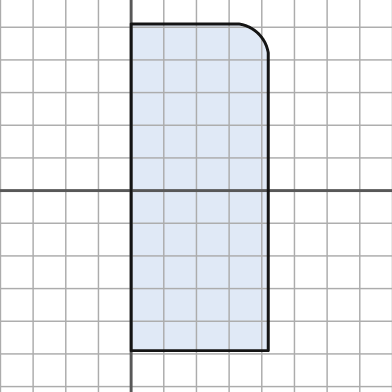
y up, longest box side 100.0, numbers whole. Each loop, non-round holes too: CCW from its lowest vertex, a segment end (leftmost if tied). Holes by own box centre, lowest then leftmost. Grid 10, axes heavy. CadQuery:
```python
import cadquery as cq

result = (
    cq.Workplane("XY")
    .moveTo(0.0, -49.0)
    .lineTo(42.0, -49.0)
    .lineTo(42.0, 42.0)
    .threePointArc((39.0, 48.0), (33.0, 51.0))
    .lineTo(0.0, 51.0)
    .close()
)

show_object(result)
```